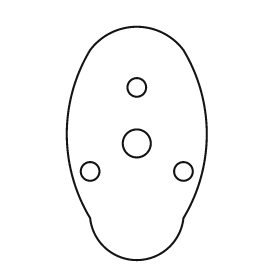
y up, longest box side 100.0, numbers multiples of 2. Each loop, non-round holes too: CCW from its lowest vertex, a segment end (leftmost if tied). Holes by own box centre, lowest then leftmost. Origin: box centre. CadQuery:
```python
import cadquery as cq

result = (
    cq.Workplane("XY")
    .moveTo(-20.0, -32.0)
    .threePointArc((0.0, -50.0), (20.0, -32.0))
    .threePointArc((30.0, 4.0), (20.0, 40.0))
    .threePointArc((0.0, 50.0), (-20.0, 40.0))
    .threePointArc((-30.0, 4.0), (-20.0, -32.0))
    .close()
    .moveTo(-20.0, -12.0)
    .circle(4.0)
    .moveTo(20.0, -12.0)
    .circle(4.0)
    .moveTo(0.0, 0.0)
    .circle(6.0)
    .moveTo(0.0, 24.0)
    .circle(4.0)
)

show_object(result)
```